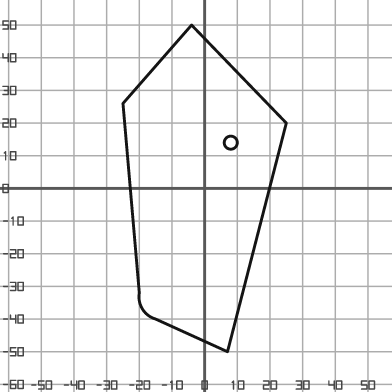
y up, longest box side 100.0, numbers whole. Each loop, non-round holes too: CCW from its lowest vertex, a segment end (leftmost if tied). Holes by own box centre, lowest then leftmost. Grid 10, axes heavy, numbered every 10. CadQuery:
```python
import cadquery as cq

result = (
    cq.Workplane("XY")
    .moveTo(7.0, -50.0)
    .lineTo(25.0, 20.0)
    .lineTo(-4.0, 50.0)
    .lineTo(-25.0, 26.0)
    .lineTo(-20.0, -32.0)
    .threePointArc((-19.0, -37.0), (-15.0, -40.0))
    .close()
    .moveTo(8.0, 14.0)
    .circle(2.0)
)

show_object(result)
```